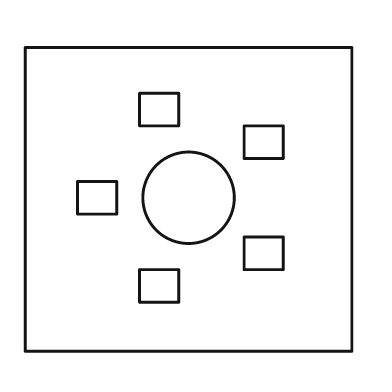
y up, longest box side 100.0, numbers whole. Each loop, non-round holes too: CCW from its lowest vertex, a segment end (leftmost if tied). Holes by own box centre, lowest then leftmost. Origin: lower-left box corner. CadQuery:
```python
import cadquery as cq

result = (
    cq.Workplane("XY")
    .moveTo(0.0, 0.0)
    .lineTo(100.0, 0.0)
    .lineTo(100.0, 93.0)
    .lineTo(0.0, 93.0)
    .close()
    .moveTo(35.0, 15.0)
    .lineTo(47.0, 15.0)
    .lineTo(47.0, 25.0)
    .lineTo(35.0, 25.0)
    .close()
    .moveTo(67.0, 25.0)
    .lineTo(79.0, 25.0)
    .lineTo(79.0, 35.0)
    .lineTo(67.0, 35.0)
    .close()
    .moveTo(16.0, 42.0)
    .lineTo(28.0, 42.0)
    .lineTo(28.0, 52.0)
    .lineTo(16.0, 52.0)
    .close()
    .moveTo(50.0, 47.0)
    .circle(14.0)
    .moveTo(67.0, 59.0)
    .lineTo(79.0, 59.0)
    .lineTo(79.0, 69.0)
    .lineTo(67.0, 69.0)
    .close()
    .moveTo(35.0, 69.0)
    .lineTo(47.0, 69.0)
    .lineTo(47.0, 79.0)
    .lineTo(35.0, 79.0)
    .close()
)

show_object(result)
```